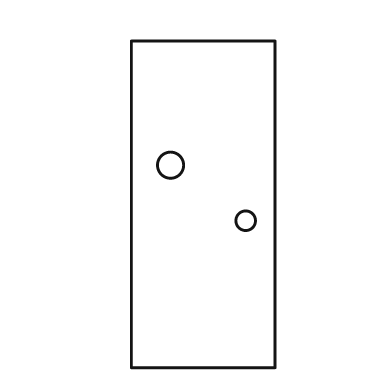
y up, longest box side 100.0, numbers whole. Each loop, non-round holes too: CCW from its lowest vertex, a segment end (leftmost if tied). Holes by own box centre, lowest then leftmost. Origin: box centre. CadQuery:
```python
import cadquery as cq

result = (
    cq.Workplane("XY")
    .moveTo(-22.0, -50.0)
    .lineTo(22.0, -50.0)
    .lineTo(22.0, 50.0)
    .lineTo(-22.0, 50.0)
    .close()
    .moveTo(13.0, -5.0)
    .circle(3.0)
    .moveTo(-10.0, 12.0)
    .circle(4.0)
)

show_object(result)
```